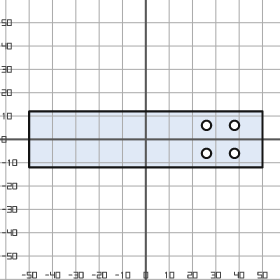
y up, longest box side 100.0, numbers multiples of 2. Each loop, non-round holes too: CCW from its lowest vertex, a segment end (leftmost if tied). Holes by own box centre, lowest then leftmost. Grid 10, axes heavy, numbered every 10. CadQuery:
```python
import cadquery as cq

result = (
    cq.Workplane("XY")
    .moveTo(-50.0, -12.0)
    .lineTo(50.0, -12.0)
    .lineTo(50.0, 12.0)
    .lineTo(-50.0, 12.0)
    .close()
    .moveTo(26.0, -6.0)
    .circle(2.0)
    .moveTo(38.0, -6.0)
    .circle(2.0)
    .moveTo(26.0, 6.0)
    .circle(2.0)
    .moveTo(38.0, 6.0)
    .circle(2.0)
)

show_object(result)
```